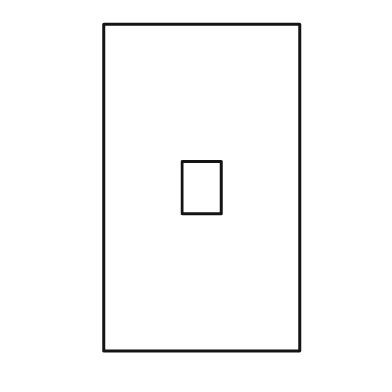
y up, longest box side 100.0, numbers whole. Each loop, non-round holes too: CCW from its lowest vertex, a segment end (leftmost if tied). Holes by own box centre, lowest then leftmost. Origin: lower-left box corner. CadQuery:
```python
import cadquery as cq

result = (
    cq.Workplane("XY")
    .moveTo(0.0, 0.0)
    .lineTo(60.0, 0.0)
    .lineTo(60.0, 100.0)
    .lineTo(0.0, 100.0)
    .close()
    .moveTo(24.0, 42.0)
    .lineTo(36.0, 42.0)
    .lineTo(36.0, 58.0)
    .lineTo(24.0, 58.0)
    .close()
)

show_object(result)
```